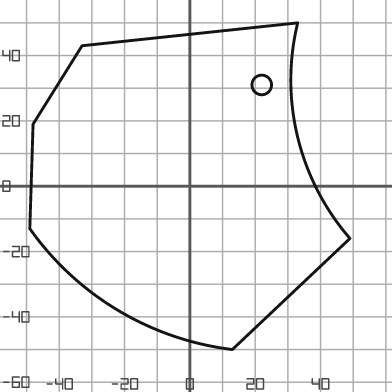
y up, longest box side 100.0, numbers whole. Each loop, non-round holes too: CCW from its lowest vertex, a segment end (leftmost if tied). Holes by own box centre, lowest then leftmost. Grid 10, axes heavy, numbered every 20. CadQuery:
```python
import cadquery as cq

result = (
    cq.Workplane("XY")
    .moveTo(13.0, -50.0)
    .lineTo(49.0, -16.0)
    .threePointArc((33.0, 15.0), (33.0, 50.0))
    .lineTo(-33.0, 43.0)
    .lineTo(-48.0, 19.0)
    .lineTo(-49.0, -13.0)
    .threePointArc((-22.0, -38.0), (13.0, -50.0))
    .close()
    .moveTo(22.0, 31.0)
    .circle(3.0)
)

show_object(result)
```